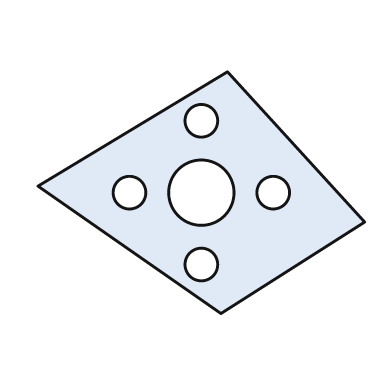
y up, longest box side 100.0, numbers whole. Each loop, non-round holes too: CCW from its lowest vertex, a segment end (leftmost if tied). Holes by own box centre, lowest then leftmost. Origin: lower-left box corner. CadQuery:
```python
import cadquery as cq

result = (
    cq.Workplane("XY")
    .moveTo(56.0, 0.0)
    .lineTo(100.0, 28.0)
    .lineTo(58.0, 74.0)
    .lineTo(0.0, 39.0)
    .close()
    .moveTo(50.0, 15.0)
    .circle(5.0)
    .moveTo(28.0, 37.0)
    .circle(5.0)
    .moveTo(50.0, 37.0)
    .circle(10.0)
    .moveTo(72.0, 37.0)
    .circle(5.0)
    .moveTo(50.0, 59.0)
    .circle(5.0)
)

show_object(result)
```